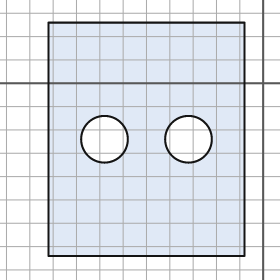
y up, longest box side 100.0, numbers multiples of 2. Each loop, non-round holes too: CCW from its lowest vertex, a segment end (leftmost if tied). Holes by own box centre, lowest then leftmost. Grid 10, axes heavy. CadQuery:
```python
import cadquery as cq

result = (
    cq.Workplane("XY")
    .moveTo(-92.0, -74.0)
    .lineTo(-8.0, -74.0)
    .lineTo(-8.0, 26.0)
    .lineTo(-92.0, 26.0)
    .close()
    .moveTo(-68.0, -24.0)
    .circle(10.0)
    .moveTo(-32.0, -24.0)
    .circle(10.0)
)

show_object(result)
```